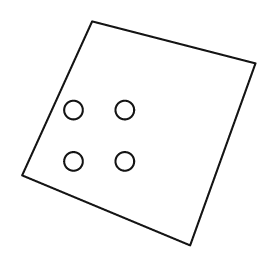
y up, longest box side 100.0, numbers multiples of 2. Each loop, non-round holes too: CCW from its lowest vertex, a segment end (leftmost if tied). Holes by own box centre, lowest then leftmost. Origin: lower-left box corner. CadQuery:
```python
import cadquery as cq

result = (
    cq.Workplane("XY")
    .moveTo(72.0, 0.0)
    .lineTo(100.0, 78.0)
    .lineTo(30.0, 96.0)
    .lineTo(0.0, 30.0)
    .close()
    .moveTo(22.0, 36.0)
    .circle(4.0)
    .moveTo(44.0, 36.0)
    .circle(4.0)
    .moveTo(22.0, 58.0)
    .circle(4.0)
    .moveTo(44.0, 58.0)
    .circle(4.0)
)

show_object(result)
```